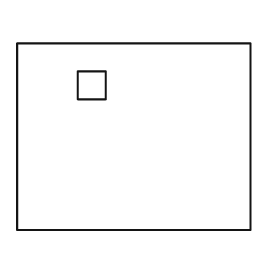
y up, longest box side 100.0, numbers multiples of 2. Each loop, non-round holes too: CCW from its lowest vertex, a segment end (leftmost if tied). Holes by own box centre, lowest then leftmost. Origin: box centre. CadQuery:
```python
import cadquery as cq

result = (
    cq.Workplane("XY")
    .moveTo(-50.0, -40.0)
    .lineTo(50.0, -40.0)
    .lineTo(50.0, 40.0)
    .lineTo(-50.0, 40.0)
    .close()
    .moveTo(-24.0, 16.0)
    .lineTo(-12.0, 16.0)
    .lineTo(-12.0, 28.0)
    .lineTo(-24.0, 28.0)
    .close()
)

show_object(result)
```